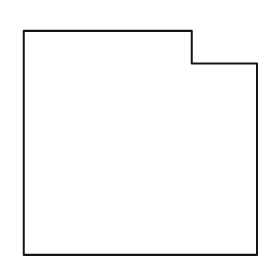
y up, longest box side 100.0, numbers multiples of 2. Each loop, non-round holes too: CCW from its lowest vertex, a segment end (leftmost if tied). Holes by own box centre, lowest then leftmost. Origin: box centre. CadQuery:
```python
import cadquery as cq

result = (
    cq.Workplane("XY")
    .moveTo(-50.0, -48.0)
    .lineTo(50.0, -48.0)
    .lineTo(50.0, 34.0)
    .lineTo(22.0, 34.0)
    .lineTo(22.0, 48.0)
    .lineTo(-50.0, 48.0)
    .close()
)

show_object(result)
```